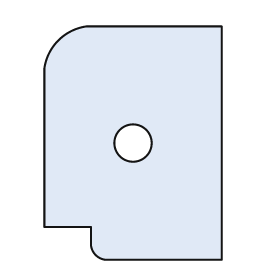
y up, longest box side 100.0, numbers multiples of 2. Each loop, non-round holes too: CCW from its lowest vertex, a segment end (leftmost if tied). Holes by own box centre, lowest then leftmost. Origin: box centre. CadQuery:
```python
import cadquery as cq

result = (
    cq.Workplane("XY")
    .moveTo(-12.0, -50.0)
    .lineTo(38.0, -50.0)
    .lineTo(38.0, 50.0)
    .lineTo(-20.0, 50.0)
    .threePointArc((-32.0, 44.0), (-38.0, 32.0))
    .lineTo(-38.0, -36.0)
    .lineTo(-18.0, -36.0)
    .lineTo(-18.0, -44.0)
    .threePointArc((-16.0, -48.0), (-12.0, -50.0))
    .close()
    .moveTo(0.0, 0.0)
    .circle(8.0)
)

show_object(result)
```